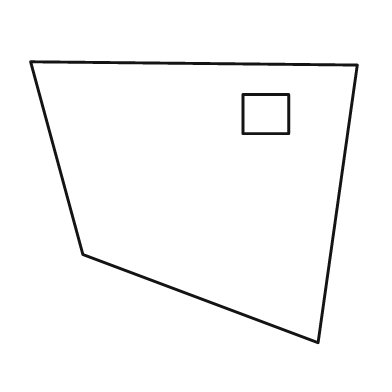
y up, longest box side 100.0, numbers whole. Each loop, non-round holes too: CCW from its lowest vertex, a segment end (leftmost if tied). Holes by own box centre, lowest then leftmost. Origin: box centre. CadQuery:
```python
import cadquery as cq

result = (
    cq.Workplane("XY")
    .moveTo(38.0, -43.0)
    .lineTo(50.0, 42.0)
    .lineTo(-50.0, 43.0)
    .lineTo(-34.0, -16.0)
    .close()
    .moveTo(15.0, 21.0)
    .lineTo(29.0, 21.0)
    .lineTo(29.0, 33.0)
    .lineTo(15.0, 33.0)
    .close()
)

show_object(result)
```